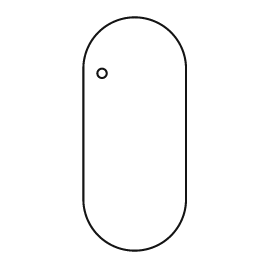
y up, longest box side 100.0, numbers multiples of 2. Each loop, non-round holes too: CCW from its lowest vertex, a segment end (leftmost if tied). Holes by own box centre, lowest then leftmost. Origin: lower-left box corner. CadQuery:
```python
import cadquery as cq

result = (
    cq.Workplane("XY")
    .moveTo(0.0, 22.0)
    .threePointArc((22.0, 0.0), (44.0, 22.0))
    .lineTo(44.0, 78.0)
    .threePointArc((22.0, 100.0), (0.0, 78.0))
    .close()
    .moveTo(8.0, 76.0)
    .circle(2.0)
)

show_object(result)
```